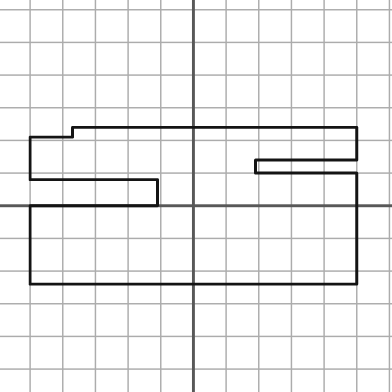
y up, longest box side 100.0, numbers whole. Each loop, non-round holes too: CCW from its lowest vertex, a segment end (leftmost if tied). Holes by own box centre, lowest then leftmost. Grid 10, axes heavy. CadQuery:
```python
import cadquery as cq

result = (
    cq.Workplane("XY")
    .moveTo(-50.0, -24.0)
    .lineTo(50.0, -24.0)
    .lineTo(50.0, 10.0)
    .lineTo(19.0, 10.0)
    .lineTo(19.0, 14.0)
    .lineTo(50.0, 14.0)
    .lineTo(50.0, 24.0)
    .lineTo(-37.0, 24.0)
    .lineTo(-37.0, 21.0)
    .lineTo(-50.0, 21.0)
    .lineTo(-50.0, 8.0)
    .lineTo(-11.0, 8.0)
    .lineTo(-11.0, 0.0)
    .lineTo(-50.0, 0.0)
    .close()
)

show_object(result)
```